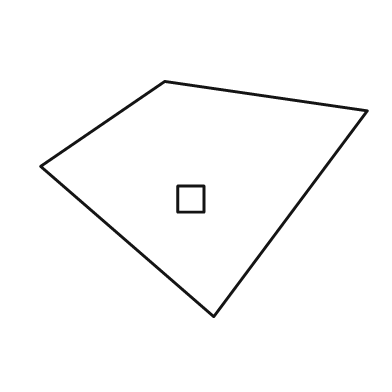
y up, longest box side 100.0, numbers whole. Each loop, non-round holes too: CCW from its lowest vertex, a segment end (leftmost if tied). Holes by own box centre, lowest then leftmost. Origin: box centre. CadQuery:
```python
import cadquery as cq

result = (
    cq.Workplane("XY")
    .moveTo(3.0, -36.0)
    .lineTo(50.0, 27.0)
    .lineTo(-12.0, 36.0)
    .lineTo(-50.0, 10.0)
    .close()
    .moveTo(-8.0, -4.0)
    .lineTo(0.0, -4.0)
    .lineTo(0.0, 4.0)
    .lineTo(-8.0, 4.0)
    .close()
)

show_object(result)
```